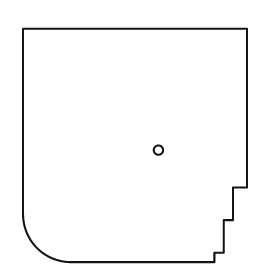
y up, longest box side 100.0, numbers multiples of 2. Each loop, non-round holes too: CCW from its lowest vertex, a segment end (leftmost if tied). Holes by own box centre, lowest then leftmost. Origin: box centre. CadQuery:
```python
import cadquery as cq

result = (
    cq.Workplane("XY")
    .moveTo(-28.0, -50.0)
    .lineTo(34.0, -50.0)
    .lineTo(34.0, -46.0)
    .lineTo(38.0, -46.0)
    .lineTo(38.0, -32.0)
    .lineTo(42.0, -32.0)
    .lineTo(42.0, -18.0)
    .lineTo(48.0, -18.0)
    .lineTo(48.0, 50.0)
    .lineTo(-48.0, 50.0)
    .lineTo(-48.0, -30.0)
    .threePointArc((-42.0, -44.0), (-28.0, -50.0))
    .close()
    .moveTo(10.0, -2.0)
    .circle(2.0)
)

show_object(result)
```